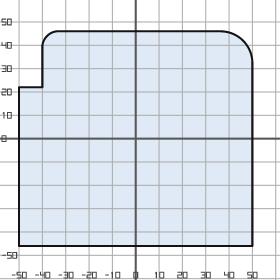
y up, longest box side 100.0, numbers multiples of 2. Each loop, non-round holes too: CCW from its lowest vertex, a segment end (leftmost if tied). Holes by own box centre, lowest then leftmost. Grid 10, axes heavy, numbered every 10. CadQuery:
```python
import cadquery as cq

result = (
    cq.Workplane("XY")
    .moveTo(-50.0, -46.0)
    .lineTo(50.0, -46.0)
    .lineTo(50.0, 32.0)
    .threePointArc((46.0, 42.0), (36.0, 46.0))
    .lineTo(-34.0, 46.0)
    .threePointArc((-38.0, 44.0), (-40.0, 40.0))
    .lineTo(-40.0, 22.0)
    .lineTo(-50.0, 22.0)
    .close()
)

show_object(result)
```